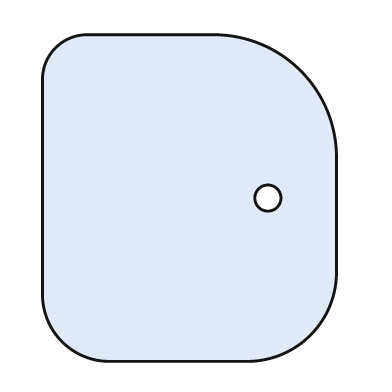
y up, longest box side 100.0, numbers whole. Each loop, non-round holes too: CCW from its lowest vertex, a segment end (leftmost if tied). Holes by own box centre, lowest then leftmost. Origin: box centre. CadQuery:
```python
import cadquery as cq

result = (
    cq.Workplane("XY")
    .moveTo(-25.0, -50.0)
    .lineTo(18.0, -50.0)
    .threePointArc((37.0, -42.0), (45.0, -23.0))
    .lineTo(45.0, 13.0)
    .threePointArc((34.0, 39.0), (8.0, 50.0))
    .lineTo(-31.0, 50.0)
    .threePointArc((-41.0, 46.0), (-45.0, 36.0))
    .lineTo(-45.0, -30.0)
    .threePointArc((-39.0, -44.0), (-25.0, -50.0))
    .close()
    .moveTo(24.0, 0.0)
    .circle(4.0)
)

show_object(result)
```